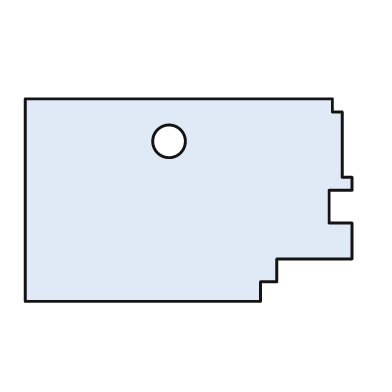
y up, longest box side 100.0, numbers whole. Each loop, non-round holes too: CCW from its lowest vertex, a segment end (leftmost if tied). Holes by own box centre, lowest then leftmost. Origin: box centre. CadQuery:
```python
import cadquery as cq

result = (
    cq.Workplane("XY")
    .moveTo(-50.0, -31.0)
    .lineTo(22.0, -31.0)
    .lineTo(22.0, -25.0)
    .lineTo(27.0, -25.0)
    .lineTo(27.0, -18.0)
    .lineTo(50.0, -18.0)
    .lineTo(50.0, -7.0)
    .lineTo(43.0, -7.0)
    .lineTo(43.0, 3.0)
    .lineTo(50.0, 3.0)
    .lineTo(50.0, 7.0)
    .lineTo(47.0, 7.0)
    .lineTo(47.0, 27.0)
    .lineTo(44.0, 27.0)
    .lineTo(44.0, 31.0)
    .lineTo(-50.0, 31.0)
    .close()
    .moveTo(-6.0, 18.0)
    .circle(5.0)
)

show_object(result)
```